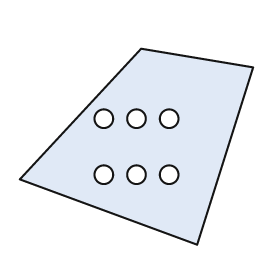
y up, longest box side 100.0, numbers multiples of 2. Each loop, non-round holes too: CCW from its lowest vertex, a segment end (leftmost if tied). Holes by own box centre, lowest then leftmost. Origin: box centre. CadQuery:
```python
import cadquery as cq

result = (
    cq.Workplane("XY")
    .moveTo(26.0, -42.0)
    .lineTo(50.0, 34.0)
    .lineTo(2.0, 42.0)
    .lineTo(-50.0, -14.0)
    .close()
    .moveTo(-14.0, -12.0)
    .circle(4.0)
    .moveTo(0.0, -12.0)
    .circle(4.0)
    .moveTo(14.0, -12.0)
    .circle(4.0)
    .moveTo(-14.0, 12.0)
    .circle(4.0)
    .moveTo(0.0, 12.0)
    .circle(4.0)
    .moveTo(14.0, 12.0)
    .circle(4.0)
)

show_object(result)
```